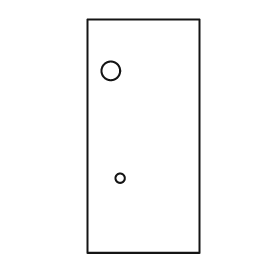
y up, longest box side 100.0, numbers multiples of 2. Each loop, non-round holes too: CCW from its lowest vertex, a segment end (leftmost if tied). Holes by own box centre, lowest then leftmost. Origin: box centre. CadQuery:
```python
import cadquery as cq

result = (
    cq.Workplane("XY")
    .moveTo(-24.0, -50.0)
    .lineTo(24.0, -50.0)
    .lineTo(24.0, 50.0)
    .lineTo(-24.0, 50.0)
    .close()
    .moveTo(-10.0, -18.0)
    .circle(2.0)
    .moveTo(-14.0, 28.0)
    .circle(4.0)
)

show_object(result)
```